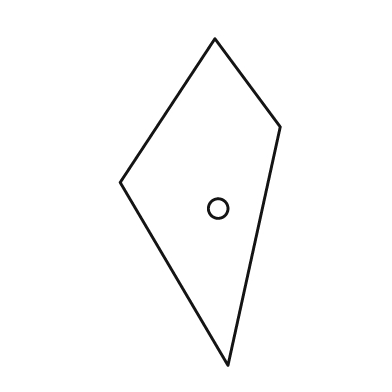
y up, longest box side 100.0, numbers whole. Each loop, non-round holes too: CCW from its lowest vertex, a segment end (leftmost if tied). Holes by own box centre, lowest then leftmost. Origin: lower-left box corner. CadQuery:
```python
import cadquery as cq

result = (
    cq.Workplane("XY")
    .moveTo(33.0, 0.0)
    .lineTo(49.0, 73.0)
    .lineTo(29.0, 100.0)
    .lineTo(0.0, 56.0)
    .close()
    .moveTo(30.0, 48.0)
    .circle(3.0)
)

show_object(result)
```